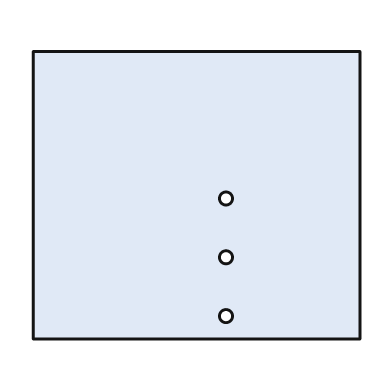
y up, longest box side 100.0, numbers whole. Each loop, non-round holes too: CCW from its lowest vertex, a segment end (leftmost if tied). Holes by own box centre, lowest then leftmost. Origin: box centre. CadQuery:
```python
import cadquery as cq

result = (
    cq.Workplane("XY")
    .moveTo(-50.0, -44.0)
    .lineTo(50.0, -44.0)
    .lineTo(50.0, 44.0)
    .lineTo(-50.0, 44.0)
    .close()
    .moveTo(9.0, -37.0)
    .circle(2.0)
    .moveTo(9.0, -19.0)
    .circle(2.0)
    .moveTo(9.0, -1.0)
    .circle(2.0)
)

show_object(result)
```